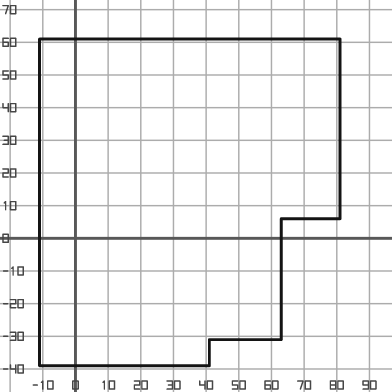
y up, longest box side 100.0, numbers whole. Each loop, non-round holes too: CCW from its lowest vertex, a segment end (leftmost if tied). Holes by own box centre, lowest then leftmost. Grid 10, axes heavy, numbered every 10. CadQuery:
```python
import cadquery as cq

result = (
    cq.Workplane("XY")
    .moveTo(-11.0, -39.0)
    .lineTo(41.0, -39.0)
    .lineTo(41.0, -31.0)
    .lineTo(63.0, -31.0)
    .lineTo(63.0, 6.0)
    .lineTo(81.0, 6.0)
    .lineTo(81.0, 61.0)
    .lineTo(-11.0, 61.0)
    .close()
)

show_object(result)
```